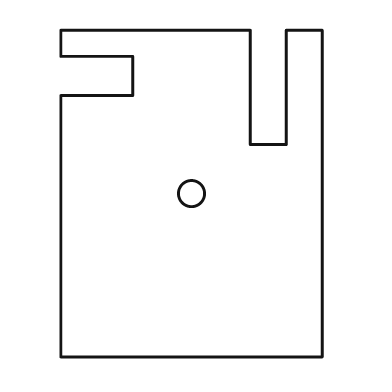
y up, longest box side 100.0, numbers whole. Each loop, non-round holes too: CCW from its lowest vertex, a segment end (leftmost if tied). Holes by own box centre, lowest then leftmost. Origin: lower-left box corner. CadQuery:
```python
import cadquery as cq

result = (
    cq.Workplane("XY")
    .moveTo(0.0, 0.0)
    .lineTo(80.0, 0.0)
    .lineTo(80.0, 100.0)
    .lineTo(69.0, 100.0)
    .lineTo(69.0, 65.0)
    .lineTo(58.0, 65.0)
    .lineTo(58.0, 100.0)
    .lineTo(0.0, 100.0)
    .lineTo(0.0, 92.0)
    .lineTo(22.0, 92.0)
    .lineTo(22.0, 80.0)
    .lineTo(0.0, 80.0)
    .close()
    .moveTo(40.0, 50.0)
    .circle(4.0)
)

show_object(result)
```